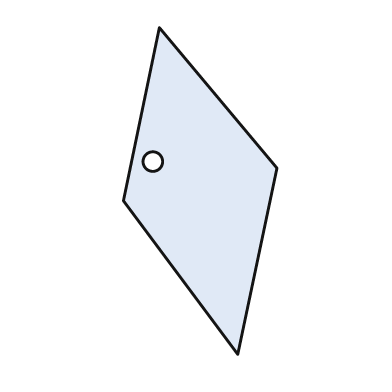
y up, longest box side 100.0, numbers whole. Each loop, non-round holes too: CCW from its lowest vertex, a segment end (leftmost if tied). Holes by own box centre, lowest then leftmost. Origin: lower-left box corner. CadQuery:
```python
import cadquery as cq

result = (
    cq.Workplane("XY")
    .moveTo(35.0, 0.0)
    .lineTo(47.0, 57.0)
    .lineTo(11.0, 100.0)
    .lineTo(0.0, 47.0)
    .close()
    .moveTo(9.0, 59.0)
    .circle(3.0)
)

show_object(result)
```